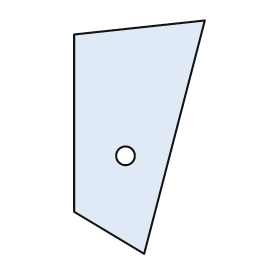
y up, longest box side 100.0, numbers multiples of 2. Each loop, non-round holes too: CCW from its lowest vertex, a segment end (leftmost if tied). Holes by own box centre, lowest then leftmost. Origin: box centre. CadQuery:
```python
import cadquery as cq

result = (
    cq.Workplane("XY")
    .moveTo(2.0, -50.0)
    .lineTo(28.0, 50.0)
    .lineTo(-28.0, 44.0)
    .lineTo(-28.0, -32.0)
    .close()
    .moveTo(-6.0, -8.0)
    .circle(4.0)
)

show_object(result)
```